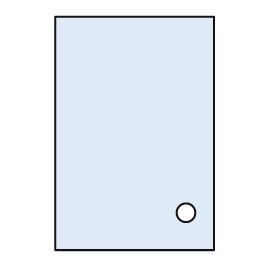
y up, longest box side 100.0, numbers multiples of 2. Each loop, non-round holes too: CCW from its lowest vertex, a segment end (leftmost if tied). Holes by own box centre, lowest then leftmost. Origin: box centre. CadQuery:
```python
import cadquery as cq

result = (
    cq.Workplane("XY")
    .moveTo(-34.0, -50.0)
    .lineTo(34.0, -50.0)
    .lineTo(34.0, 50.0)
    .lineTo(-34.0, 50.0)
    .close()
    .moveTo(22.0, -34.0)
    .circle(4.0)
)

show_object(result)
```